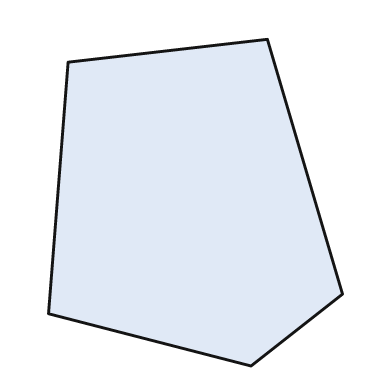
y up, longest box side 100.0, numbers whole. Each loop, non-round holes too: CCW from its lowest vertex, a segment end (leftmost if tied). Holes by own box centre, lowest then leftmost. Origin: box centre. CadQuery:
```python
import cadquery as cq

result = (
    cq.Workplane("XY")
    .moveTo(17.0, -50.0)
    .lineTo(45.0, -28.0)
    .lineTo(22.0, 50.0)
    .lineTo(-39.0, 43.0)
    .lineTo(-45.0, -34.0)
    .close()
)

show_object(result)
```